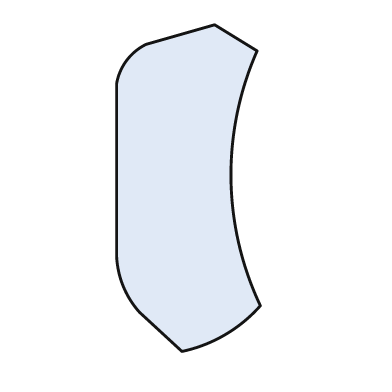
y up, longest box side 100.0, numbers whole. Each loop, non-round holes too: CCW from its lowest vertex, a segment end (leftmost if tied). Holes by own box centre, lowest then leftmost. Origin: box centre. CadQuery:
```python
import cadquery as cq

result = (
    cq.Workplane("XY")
    .moveTo(-2.0, -50.0)
    .threePointArc((11.0, -45.0), (22.0, -36.0))
    .threePointArc((13.0, 3.0), (21.0, 42.0))
    .lineTo(8.0, 50.0)
    .lineTo(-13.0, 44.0)
    .threePointArc((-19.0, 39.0), (-22.0, 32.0))
    .lineTo(-22.0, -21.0)
    .threePointArc((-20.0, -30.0), (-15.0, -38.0))
    .close()
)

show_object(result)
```